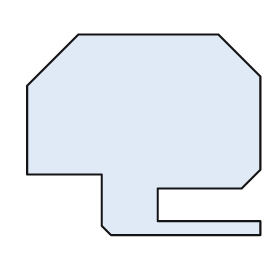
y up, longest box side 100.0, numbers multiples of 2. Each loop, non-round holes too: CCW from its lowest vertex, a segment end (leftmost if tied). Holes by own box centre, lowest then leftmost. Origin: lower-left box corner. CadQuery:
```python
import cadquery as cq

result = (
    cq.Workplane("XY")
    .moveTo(36.0, 0.0)
    .lineTo(100.0, 0.0)
    .lineTo(100.0, 6.0)
    .lineTo(56.0, 6.0)
    .lineTo(56.0, 20.0)
    .lineTo(92.0, 20.0)
    .lineTo(100.0, 28.0)
    .lineTo(100.0, 68.0)
    .lineTo(82.0, 86.0)
    .lineTo(22.0, 86.0)
    .lineTo(0.0, 64.0)
    .lineTo(0.0, 26.0)
    .lineTo(32.0, 26.0)
    .lineTo(32.0, 4.0)
    .close()
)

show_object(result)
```